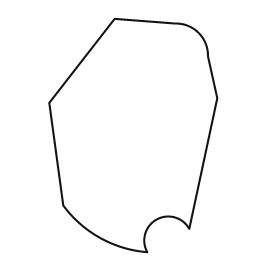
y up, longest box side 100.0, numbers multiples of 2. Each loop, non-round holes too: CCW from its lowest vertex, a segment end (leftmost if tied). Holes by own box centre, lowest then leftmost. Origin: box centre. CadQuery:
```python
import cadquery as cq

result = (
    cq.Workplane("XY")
    .moveTo(6.0, -50.0)
    .threePointArc((10.0, -36.0), (24.0, -40.0))
    .lineTo(36.0, 16.0)
    .lineTo(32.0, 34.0)
    .threePointArc((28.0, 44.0), (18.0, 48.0))
    .lineTo(-8.0, 50.0)
    .lineTo(-36.0, 14.0)
    .lineTo(-30.0, -30.0)
    .threePointArc((-14.0, -44.0), (6.0, -50.0))
    .close()
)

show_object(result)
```